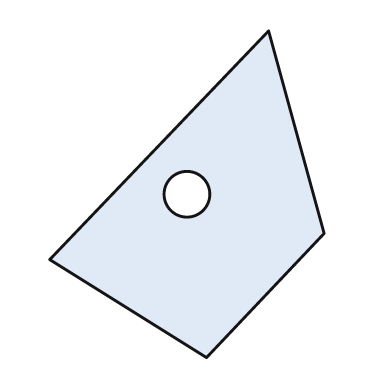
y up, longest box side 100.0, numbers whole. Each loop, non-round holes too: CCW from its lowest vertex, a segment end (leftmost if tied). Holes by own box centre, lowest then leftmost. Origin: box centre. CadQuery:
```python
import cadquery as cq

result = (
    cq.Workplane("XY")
    .moveTo(6.0, -50.0)
    .lineTo(42.0, -12.0)
    .lineTo(25.0, 50.0)
    .lineTo(-42.0, -20.0)
    .close()
    .moveTo(0.0, 0.0)
    .circle(7.0)
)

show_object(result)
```